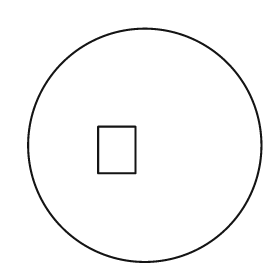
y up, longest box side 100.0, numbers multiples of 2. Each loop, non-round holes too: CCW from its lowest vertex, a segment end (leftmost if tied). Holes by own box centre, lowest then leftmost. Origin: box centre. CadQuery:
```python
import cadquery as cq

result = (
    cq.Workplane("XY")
    .moveTo(0.0, 0.0)
    .circle(50.0)
    .moveTo(-20.0, -12.0)
    .lineTo(-4.0, -12.0)
    .lineTo(-4.0, 8.0)
    .lineTo(-20.0, 8.0)
    .close()
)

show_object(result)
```